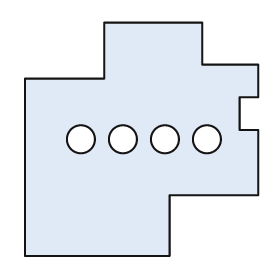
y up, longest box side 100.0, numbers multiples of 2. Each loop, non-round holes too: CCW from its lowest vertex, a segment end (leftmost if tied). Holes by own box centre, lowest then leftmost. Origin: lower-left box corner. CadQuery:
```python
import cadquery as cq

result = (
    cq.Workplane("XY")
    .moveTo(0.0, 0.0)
    .lineTo(62.0, 0.0)
    .lineTo(62.0, 26.0)
    .lineTo(100.0, 26.0)
    .lineTo(100.0, 54.0)
    .lineTo(92.0, 54.0)
    .lineTo(92.0, 68.0)
    .lineTo(100.0, 68.0)
    .lineTo(100.0, 82.0)
    .lineTo(76.0, 82.0)
    .lineTo(76.0, 100.0)
    .lineTo(34.0, 100.0)
    .lineTo(34.0, 76.0)
    .lineTo(0.0, 76.0)
    .close()
    .moveTo(24.0, 50.0)
    .circle(6.0)
    .moveTo(42.0, 50.0)
    .circle(6.0)
    .moveTo(60.0, 50.0)
    .circle(6.0)
    .moveTo(78.0, 50.0)
    .circle(6.0)
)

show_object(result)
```